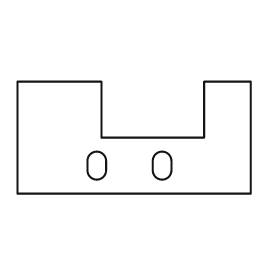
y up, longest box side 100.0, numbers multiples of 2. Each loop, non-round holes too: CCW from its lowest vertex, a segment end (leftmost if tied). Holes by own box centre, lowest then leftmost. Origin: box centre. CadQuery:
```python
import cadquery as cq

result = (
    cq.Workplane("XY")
    .moveTo(-50.0, -24.0)
    .lineTo(50.0, -24.0)
    .lineTo(50.0, 24.0)
    .lineTo(30.0, 24.0)
    .lineTo(30.0, 0.0)
    .lineTo(-14.0, 0.0)
    .lineTo(-14.0, 24.0)
    .lineTo(-50.0, 24.0)
    .close()
    .moveTo(-20.0, -14.0)
    .threePointArc((-16.0, -18.0), (-12.0, -14.0))
    .lineTo(-12.0, -10.0)
    .threePointArc((-16.0, -6.0), (-20.0, -10.0))
    .close()
    .moveTo(8.0, -14.0)
    .threePointArc((12.0, -18.0), (16.0, -14.0))
    .lineTo(16.0, -10.0)
    .threePointArc((12.0, -6.0), (8.0, -10.0))
    .close()
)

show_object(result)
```